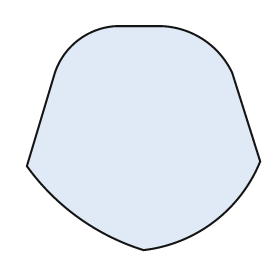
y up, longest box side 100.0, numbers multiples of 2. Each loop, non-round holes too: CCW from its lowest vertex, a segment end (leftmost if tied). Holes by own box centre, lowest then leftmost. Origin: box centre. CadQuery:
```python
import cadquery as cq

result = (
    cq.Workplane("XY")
    .moveTo(0.0, -48.0)
    .threePointArc((30.0, -36.0), (50.0, -10.0))
    .lineTo(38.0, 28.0)
    .threePointArc((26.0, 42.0), (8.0, 48.0))
    .lineTo(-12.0, 48.0)
    .threePointArc((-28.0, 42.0), (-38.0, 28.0))
    .lineTo(-50.0, -12.0)
    .threePointArc((-28.0, -34.0), (0.0, -48.0))
    .close()
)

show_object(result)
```